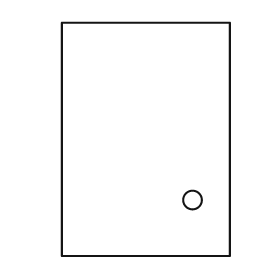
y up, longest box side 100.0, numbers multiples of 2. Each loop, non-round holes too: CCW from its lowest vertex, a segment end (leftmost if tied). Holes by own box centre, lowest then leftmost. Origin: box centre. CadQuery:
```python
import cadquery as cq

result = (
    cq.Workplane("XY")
    .moveTo(-36.0, -50.0)
    .lineTo(36.0, -50.0)
    .lineTo(36.0, 50.0)
    .lineTo(-36.0, 50.0)
    .close()
    .moveTo(20.0, -26.0)
    .circle(4.0)
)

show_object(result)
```